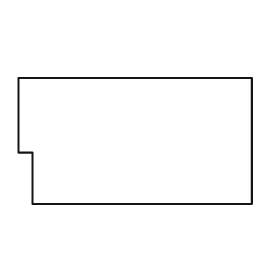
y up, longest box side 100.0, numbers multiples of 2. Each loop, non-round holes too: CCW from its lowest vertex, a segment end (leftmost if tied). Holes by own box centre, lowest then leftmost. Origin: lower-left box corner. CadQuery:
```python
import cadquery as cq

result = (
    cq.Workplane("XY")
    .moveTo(6.0, 0.0)
    .lineTo(100.0, 0.0)
    .lineTo(100.0, 54.0)
    .lineTo(0.0, 54.0)
    .lineTo(0.0, 22.0)
    .lineTo(6.0, 22.0)
    .close()
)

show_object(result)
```